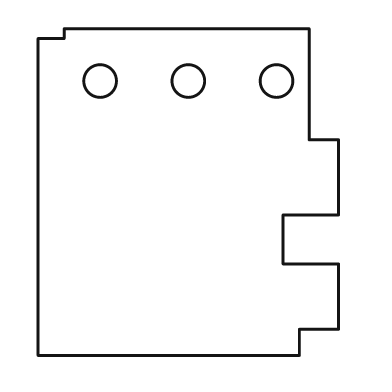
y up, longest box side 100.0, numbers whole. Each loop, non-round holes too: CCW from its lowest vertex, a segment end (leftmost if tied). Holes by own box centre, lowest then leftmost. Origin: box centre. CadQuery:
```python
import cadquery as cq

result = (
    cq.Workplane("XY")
    .moveTo(-46.0, -50.0)
    .lineTo(34.0, -50.0)
    .lineTo(34.0, -42.0)
    .lineTo(46.0, -42.0)
    .lineTo(46.0, -22.0)
    .lineTo(29.0, -22.0)
    .lineTo(29.0, -7.0)
    .lineTo(46.0, -7.0)
    .lineTo(46.0, 16.0)
    .lineTo(37.0, 16.0)
    .lineTo(37.0, 50.0)
    .lineTo(-38.0, 50.0)
    .lineTo(-38.0, 47.0)
    .lineTo(-46.0, 47.0)
    .close()
    .moveTo(-27.0, 34.0)
    .circle(5.0)
    .moveTo(0.0, 34.0)
    .circle(5.0)
    .moveTo(27.0, 34.0)
    .circle(5.0)
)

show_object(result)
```